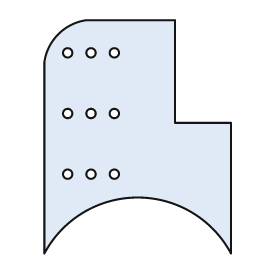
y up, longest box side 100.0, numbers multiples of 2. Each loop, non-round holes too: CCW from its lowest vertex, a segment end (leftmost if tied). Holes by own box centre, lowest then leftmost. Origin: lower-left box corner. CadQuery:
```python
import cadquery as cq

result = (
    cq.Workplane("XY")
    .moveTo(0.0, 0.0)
    .threePointArc((40.0, 24.0), (80.0, 0.0))
    .lineTo(80.0, 56.0)
    .lineTo(56.0, 56.0)
    .lineTo(56.0, 100.0)
    .lineTo(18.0, 100.0)
    .threePointArc((6.0, 94.0), (0.0, 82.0))
    .close()
    .moveTo(10.0, 34.0)
    .circle(2.0)
    .moveTo(20.0, 34.0)
    .circle(2.0)
    .moveTo(30.0, 34.0)
    .circle(2.0)
    .moveTo(10.0, 60.0)
    .circle(2.0)
    .moveTo(20.0, 60.0)
    .circle(2.0)
    .moveTo(30.0, 60.0)
    .circle(2.0)
    .moveTo(10.0, 86.0)
    .circle(2.0)
    .moveTo(20.0, 86.0)
    .circle(2.0)
    .moveTo(30.0, 86.0)
    .circle(2.0)
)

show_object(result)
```